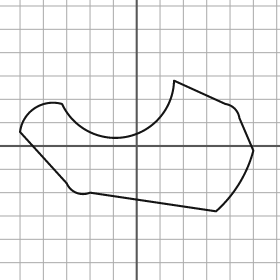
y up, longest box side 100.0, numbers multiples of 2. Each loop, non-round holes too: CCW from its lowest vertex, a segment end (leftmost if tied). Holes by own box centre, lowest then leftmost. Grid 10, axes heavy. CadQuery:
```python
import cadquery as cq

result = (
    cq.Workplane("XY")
    .moveTo(34.0, -28.0)
    .threePointArc((44.0, -16.0), (50.0, -2.0))
    .lineTo(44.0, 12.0)
    .threePointArc((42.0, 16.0), (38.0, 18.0))
    .lineTo(16.0, 28.0)
    .threePointArc((-4.0, 4.0), (-32.0, 18.0))
    .threePointArc((-44.0, 16.0), (-50.0, 6.0))
    .lineTo(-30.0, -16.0)
    .threePointArc((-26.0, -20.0), (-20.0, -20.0))
    .close()
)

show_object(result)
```